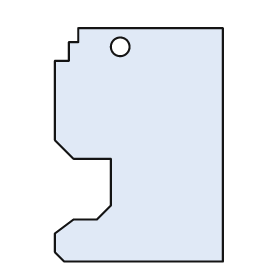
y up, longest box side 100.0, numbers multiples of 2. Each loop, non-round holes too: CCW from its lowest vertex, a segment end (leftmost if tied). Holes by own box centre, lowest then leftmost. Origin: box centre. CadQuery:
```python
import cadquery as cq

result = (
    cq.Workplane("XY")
    .moveTo(-32.0, -50.0)
    .lineTo(36.0, -50.0)
    .lineTo(36.0, 50.0)
    .lineTo(-26.0, 50.0)
    .lineTo(-26.0, 44.0)
    .lineTo(-30.0, 44.0)
    .lineTo(-30.0, 36.0)
    .lineTo(-36.0, 36.0)
    .lineTo(-36.0, 2.0)
    .lineTo(-28.0, -6.0)
    .lineTo(-12.0, -6.0)
    .lineTo(-12.0, -26.0)
    .lineTo(-18.0, -32.0)
    .lineTo(-28.0, -32.0)
    .lineTo(-36.0, -38.0)
    .lineTo(-36.0, -46.0)
    .close()
    .moveTo(-8.0, 42.0)
    .circle(4.0)
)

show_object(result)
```